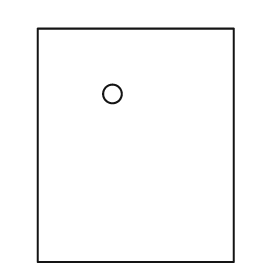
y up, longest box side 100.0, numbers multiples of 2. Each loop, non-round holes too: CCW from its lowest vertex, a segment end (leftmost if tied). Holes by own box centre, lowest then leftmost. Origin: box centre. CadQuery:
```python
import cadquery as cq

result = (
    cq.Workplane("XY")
    .moveTo(-42.0, -50.0)
    .lineTo(42.0, -50.0)
    .lineTo(42.0, 50.0)
    .lineTo(-42.0, 50.0)
    .close()
    .moveTo(-10.0, 22.0)
    .circle(4.0)
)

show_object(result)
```